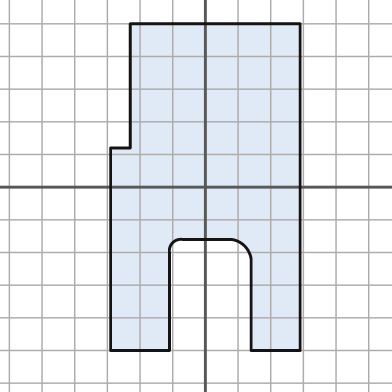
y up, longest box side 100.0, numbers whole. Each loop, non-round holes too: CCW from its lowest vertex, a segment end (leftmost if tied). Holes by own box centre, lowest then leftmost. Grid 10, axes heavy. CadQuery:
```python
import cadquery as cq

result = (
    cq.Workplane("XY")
    .moveTo(-29.0, -50.0)
    .lineTo(-11.0, -50.0)
    .lineTo(-11.0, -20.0)
    .threePointArc((-10.0, -17.0), (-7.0, -16.0))
    .lineTo(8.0, -16.0)
    .threePointArc((12.0, -18.0), (14.0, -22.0))
    .lineTo(14.0, -50.0)
    .lineTo(29.0, -50.0)
    .lineTo(29.0, 50.0)
    .lineTo(-23.0, 50.0)
    .lineTo(-23.0, 12.0)
    .lineTo(-29.0, 12.0)
    .close()
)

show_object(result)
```